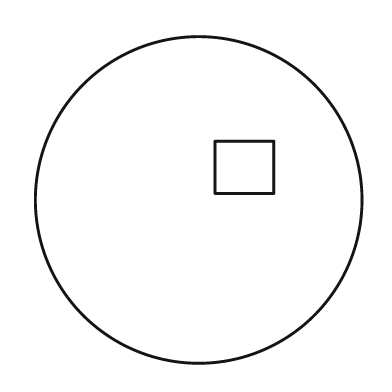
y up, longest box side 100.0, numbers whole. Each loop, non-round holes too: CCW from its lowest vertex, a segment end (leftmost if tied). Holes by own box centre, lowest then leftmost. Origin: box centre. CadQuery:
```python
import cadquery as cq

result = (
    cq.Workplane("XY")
    .moveTo(0.0, 0.0)
    .circle(50.0)
    .moveTo(5.0, 2.0)
    .lineTo(23.0, 2.0)
    .lineTo(23.0, 18.0)
    .lineTo(5.0, 18.0)
    .close()
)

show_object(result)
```